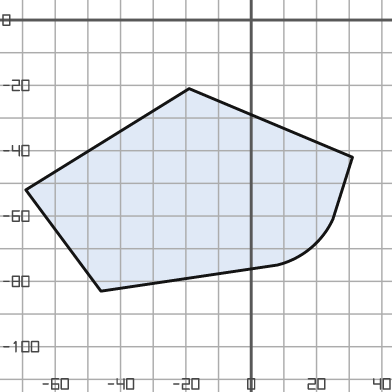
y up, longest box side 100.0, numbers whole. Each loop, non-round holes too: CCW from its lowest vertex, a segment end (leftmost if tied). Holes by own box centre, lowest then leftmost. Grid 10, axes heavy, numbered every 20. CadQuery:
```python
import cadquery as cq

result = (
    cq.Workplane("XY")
    .moveTo(-46.0, -83.0)
    .lineTo(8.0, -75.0)
    .threePointArc((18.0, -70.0), (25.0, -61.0))
    .lineTo(31.0, -42.0)
    .lineTo(-19.0, -21.0)
    .lineTo(-69.0, -52.0)
    .close()
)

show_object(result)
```